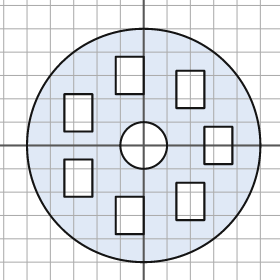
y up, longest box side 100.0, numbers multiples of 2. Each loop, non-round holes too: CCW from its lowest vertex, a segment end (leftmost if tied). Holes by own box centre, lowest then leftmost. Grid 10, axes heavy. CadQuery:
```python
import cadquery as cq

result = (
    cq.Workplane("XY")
    .moveTo(0.0, 0.0)
    .circle(50.0)
    .moveTo(-12.0, -38.0)
    .lineTo(0.0, -38.0)
    .lineTo(0.0, -22.0)
    .lineTo(-12.0, -22.0)
    .close()
    .moveTo(14.0, -32.0)
    .lineTo(26.0, -32.0)
    .lineTo(26.0, -16.0)
    .lineTo(14.0, -16.0)
    .close()
    .moveTo(-34.0, -22.0)
    .lineTo(-22.0, -22.0)
    .lineTo(-22.0, -6.0)
    .lineTo(-34.0, -6.0)
    .close()
    .moveTo(0.0, 0.0)
    .circle(10.0)
    .moveTo(26.0, -8.0)
    .lineTo(38.0, -8.0)
    .lineTo(38.0, 8.0)
    .lineTo(26.0, 8.0)
    .close()
    .moveTo(-34.0, 6.0)
    .lineTo(-22.0, 6.0)
    .lineTo(-22.0, 22.0)
    .lineTo(-34.0, 22.0)
    .close()
    .moveTo(14.0, 16.0)
    .lineTo(26.0, 16.0)
    .lineTo(26.0, 32.0)
    .lineTo(14.0, 32.0)
    .close()
    .moveTo(-12.0, 22.0)
    .lineTo(0.0, 22.0)
    .lineTo(0.0, 38.0)
    .lineTo(-12.0, 38.0)
    .close()
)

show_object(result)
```